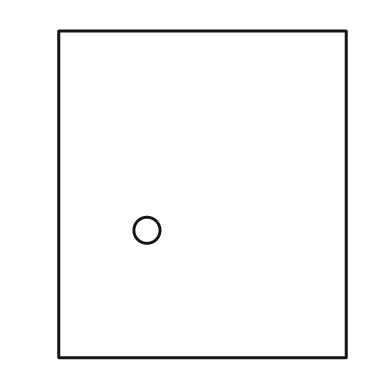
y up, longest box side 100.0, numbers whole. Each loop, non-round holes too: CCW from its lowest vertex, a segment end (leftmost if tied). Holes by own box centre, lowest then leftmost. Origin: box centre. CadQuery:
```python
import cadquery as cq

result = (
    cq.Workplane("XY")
    .moveTo(-44.0, -50.0)
    .lineTo(44.0, -50.0)
    .lineTo(44.0, 50.0)
    .lineTo(-44.0, 50.0)
    .close()
    .moveTo(-17.0, -11.0)
    .circle(4.0)
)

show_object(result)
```